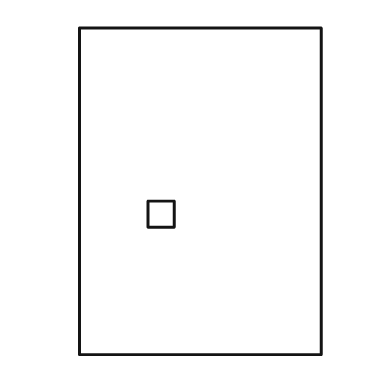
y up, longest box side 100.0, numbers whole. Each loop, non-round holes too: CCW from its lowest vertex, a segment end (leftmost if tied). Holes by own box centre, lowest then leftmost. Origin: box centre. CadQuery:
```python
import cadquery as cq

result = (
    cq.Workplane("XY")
    .moveTo(-37.0, -50.0)
    .lineTo(37.0, -50.0)
    .lineTo(37.0, 50.0)
    .lineTo(-37.0, 50.0)
    .close()
    .moveTo(-16.0, -11.0)
    .lineTo(-8.0, -11.0)
    .lineTo(-8.0, -3.0)
    .lineTo(-16.0, -3.0)
    .close()
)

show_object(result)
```